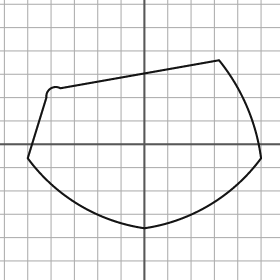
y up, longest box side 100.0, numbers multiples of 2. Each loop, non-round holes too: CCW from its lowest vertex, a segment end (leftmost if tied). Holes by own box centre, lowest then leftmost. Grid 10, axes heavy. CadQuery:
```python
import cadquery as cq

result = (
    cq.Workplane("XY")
    .moveTo(0.0, -36.0)
    .threePointArc((28.0, -26.0), (50.0, -6.0))
    .threePointArc((44.0, 16.0), (32.0, 36.0))
    .lineTo(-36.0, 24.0)
    .threePointArc((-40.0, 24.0), (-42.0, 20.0))
    .lineTo(-50.0, -6.0)
    .threePointArc((-28.0, -26.0), (0.0, -36.0))
    .close()
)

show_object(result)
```